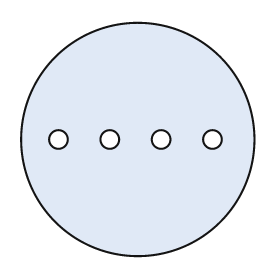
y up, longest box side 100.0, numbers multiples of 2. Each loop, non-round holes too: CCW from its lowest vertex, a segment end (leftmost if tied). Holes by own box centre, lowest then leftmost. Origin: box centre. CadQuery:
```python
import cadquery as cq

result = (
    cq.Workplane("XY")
    .moveTo(0.0, 0.0)
    .circle(50.0)
    .moveTo(-34.0, 0.0)
    .circle(4.0)
    .moveTo(-12.0, 0.0)
    .circle(4.0)
    .moveTo(10.0, 0.0)
    .circle(4.0)
    .moveTo(32.0, 0.0)
    .circle(4.0)
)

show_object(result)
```